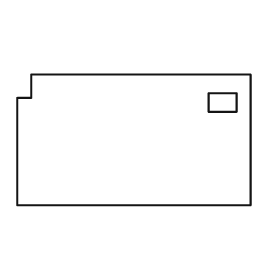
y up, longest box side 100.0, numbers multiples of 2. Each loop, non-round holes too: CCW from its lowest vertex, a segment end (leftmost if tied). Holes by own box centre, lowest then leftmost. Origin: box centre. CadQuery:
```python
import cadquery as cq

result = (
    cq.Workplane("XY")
    .moveTo(-50.0, -28.0)
    .lineTo(50.0, -28.0)
    .lineTo(50.0, 28.0)
    .lineTo(-44.0, 28.0)
    .lineTo(-44.0, 18.0)
    .lineTo(-50.0, 18.0)
    .close()
    .moveTo(32.0, 12.0)
    .lineTo(44.0, 12.0)
    .lineTo(44.0, 20.0)
    .lineTo(32.0, 20.0)
    .close()
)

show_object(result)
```